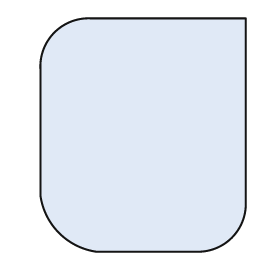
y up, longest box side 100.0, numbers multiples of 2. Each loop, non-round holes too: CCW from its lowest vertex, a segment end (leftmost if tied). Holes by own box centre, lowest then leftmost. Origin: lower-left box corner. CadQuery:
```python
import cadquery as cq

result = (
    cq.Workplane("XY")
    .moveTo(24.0, 0.0)
    .lineTo(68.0, 0.0)
    .threePointArc((82.0, 6.0), (88.0, 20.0))
    .lineTo(88.0, 100.0)
    .lineTo(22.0, 100.0)
    .threePointArc((6.0, 94.0), (0.0, 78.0))
    .lineTo(0.0, 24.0)
    .threePointArc((8.0, 8.0), (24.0, 0.0))
    .close()
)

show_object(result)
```